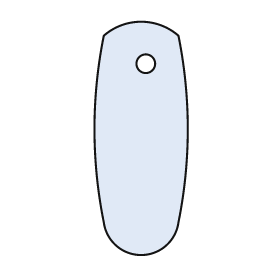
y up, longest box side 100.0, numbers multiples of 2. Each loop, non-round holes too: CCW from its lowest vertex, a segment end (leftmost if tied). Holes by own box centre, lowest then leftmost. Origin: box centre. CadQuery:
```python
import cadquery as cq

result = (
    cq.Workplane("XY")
    .moveTo(-16.0, -36.0)
    .threePointArc((0.0, -50.0), (16.0, -36.0))
    .threePointArc((20.0, 4.0), (16.0, 44.0))
    .threePointArc((0.0, 50.0), (-16.0, 44.0))
    .threePointArc((-20.0, 4.0), (-16.0, -36.0))
    .close()
    .moveTo(2.0, 32.0)
    .circle(4.0)
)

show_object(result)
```